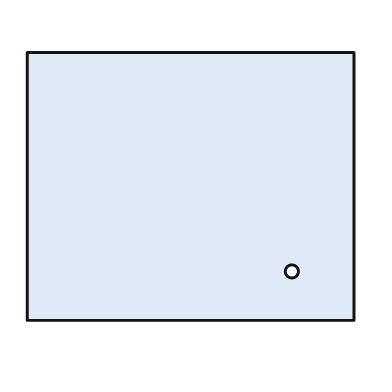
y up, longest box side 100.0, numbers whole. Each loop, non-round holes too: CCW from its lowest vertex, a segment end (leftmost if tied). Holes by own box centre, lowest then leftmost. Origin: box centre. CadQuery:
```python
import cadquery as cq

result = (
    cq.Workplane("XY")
    .moveTo(-50.0, -41.0)
    .lineTo(50.0, -41.0)
    .lineTo(50.0, 41.0)
    .lineTo(-50.0, 41.0)
    .close()
    .moveTo(31.0, -26.0)
    .circle(2.0)
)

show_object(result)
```